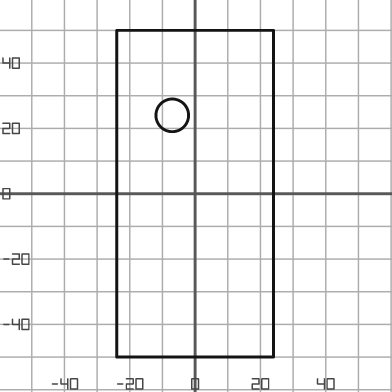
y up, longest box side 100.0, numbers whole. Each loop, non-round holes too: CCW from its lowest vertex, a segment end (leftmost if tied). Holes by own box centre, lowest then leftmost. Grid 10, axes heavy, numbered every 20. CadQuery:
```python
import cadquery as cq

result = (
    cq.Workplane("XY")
    .moveTo(-24.0, -50.0)
    .lineTo(24.0, -50.0)
    .lineTo(24.0, 50.0)
    .lineTo(-24.0, 50.0)
    .close()
    .moveTo(-7.0, 24.0)
    .circle(5.0)
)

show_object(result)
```